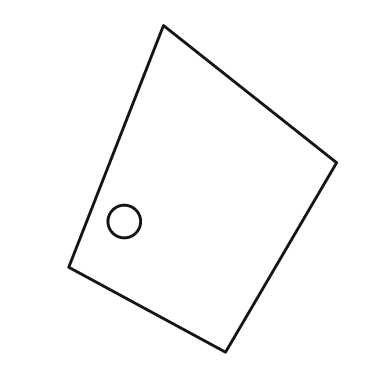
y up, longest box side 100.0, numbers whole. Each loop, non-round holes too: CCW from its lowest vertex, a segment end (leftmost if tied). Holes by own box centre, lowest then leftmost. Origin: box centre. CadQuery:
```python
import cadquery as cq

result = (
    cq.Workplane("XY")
    .moveTo(7.0, -50.0)
    .lineTo(41.0, 8.0)
    .lineTo(-12.0, 50.0)
    .lineTo(-41.0, -24.0)
    .close()
    .moveTo(-24.0, -10.0)
    .circle(5.0)
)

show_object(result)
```